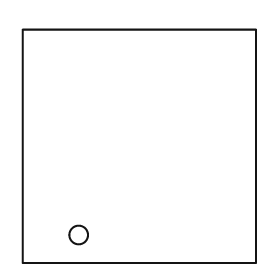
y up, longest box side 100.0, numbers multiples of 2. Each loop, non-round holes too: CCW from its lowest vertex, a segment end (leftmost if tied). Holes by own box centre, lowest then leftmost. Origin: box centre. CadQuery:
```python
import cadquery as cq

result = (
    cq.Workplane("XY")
    .moveTo(-50.0, -50.0)
    .lineTo(50.0, -50.0)
    .lineTo(50.0, 50.0)
    .lineTo(-50.0, 50.0)
    .close()
    .moveTo(-26.0, -38.0)
    .circle(4.0)
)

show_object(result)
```